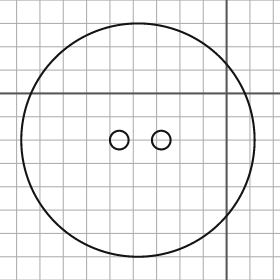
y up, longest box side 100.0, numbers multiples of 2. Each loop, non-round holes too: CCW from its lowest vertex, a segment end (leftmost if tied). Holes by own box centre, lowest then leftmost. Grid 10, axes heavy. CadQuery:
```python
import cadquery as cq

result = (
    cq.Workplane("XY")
    .moveTo(-38.0, -20.0)
    .circle(50.0)
    .moveTo(-46.0, -20.0)
    .circle(4.0)
    .moveTo(-28.0, -20.0)
    .circle(4.0)
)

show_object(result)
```